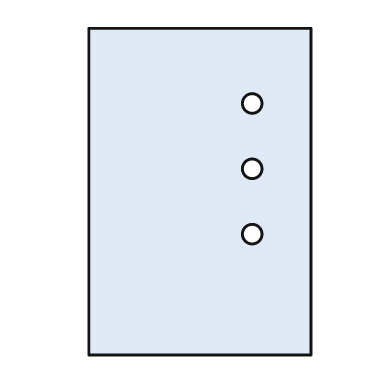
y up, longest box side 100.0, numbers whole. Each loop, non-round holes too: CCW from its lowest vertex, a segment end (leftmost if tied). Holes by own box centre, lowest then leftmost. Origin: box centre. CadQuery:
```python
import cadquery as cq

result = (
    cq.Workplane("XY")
    .moveTo(-34.0, -50.0)
    .lineTo(34.0, -50.0)
    .lineTo(34.0, 50.0)
    .lineTo(-34.0, 50.0)
    .close()
    .moveTo(16.0, -13.0)
    .circle(3.0)
    .moveTo(16.0, 7.0)
    .circle(3.0)
    .moveTo(16.0, 27.0)
    .circle(3.0)
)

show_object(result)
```